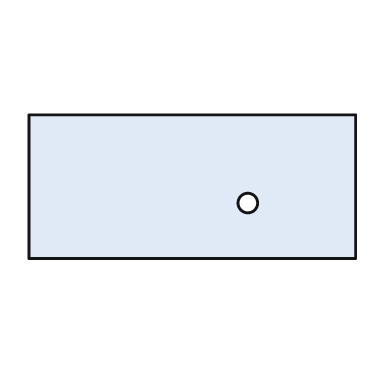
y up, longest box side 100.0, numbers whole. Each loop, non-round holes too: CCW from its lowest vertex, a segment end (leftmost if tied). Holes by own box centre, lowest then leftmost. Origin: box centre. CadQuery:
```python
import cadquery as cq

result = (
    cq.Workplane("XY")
    .moveTo(-50.0, -22.0)
    .lineTo(50.0, -22.0)
    .lineTo(50.0, 22.0)
    .lineTo(-50.0, 22.0)
    .close()
    .moveTo(17.0, -5.0)
    .circle(3.0)
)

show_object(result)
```